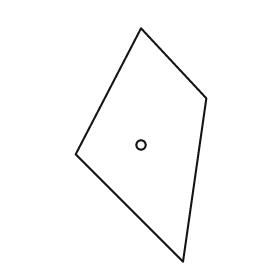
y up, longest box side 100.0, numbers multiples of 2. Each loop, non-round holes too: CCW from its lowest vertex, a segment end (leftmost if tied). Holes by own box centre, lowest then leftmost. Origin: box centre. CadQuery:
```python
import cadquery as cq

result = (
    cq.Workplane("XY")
    .moveTo(18.0, -50.0)
    .lineTo(28.0, 20.0)
    .lineTo(0.0, 50.0)
    .lineTo(-28.0, -4.0)
    .close()
    .moveTo(0.0, 0.0)
    .circle(2.0)
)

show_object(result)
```